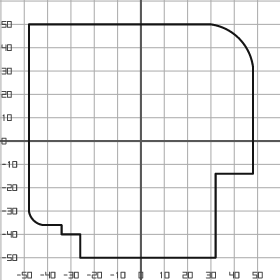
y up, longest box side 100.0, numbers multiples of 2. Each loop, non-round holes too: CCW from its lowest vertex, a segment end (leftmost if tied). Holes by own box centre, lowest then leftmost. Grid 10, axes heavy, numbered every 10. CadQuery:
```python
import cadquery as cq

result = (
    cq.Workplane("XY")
    .moveTo(-26.0, -50.0)
    .lineTo(32.0, -50.0)
    .lineTo(32.0, -14.0)
    .lineTo(48.0, -14.0)
    .lineTo(48.0, 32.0)
    .threePointArc((42.0, 44.0), (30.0, 50.0))
    .lineTo(-48.0, 50.0)
    .lineTo(-48.0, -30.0)
    .threePointArc((-46.0, -34.0), (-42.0, -36.0))
    .lineTo(-34.0, -36.0)
    .lineTo(-34.0, -40.0)
    .lineTo(-26.0, -40.0)
    .close()
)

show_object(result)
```